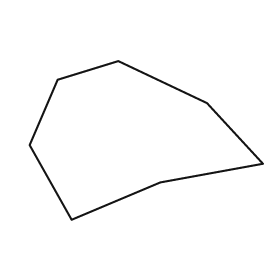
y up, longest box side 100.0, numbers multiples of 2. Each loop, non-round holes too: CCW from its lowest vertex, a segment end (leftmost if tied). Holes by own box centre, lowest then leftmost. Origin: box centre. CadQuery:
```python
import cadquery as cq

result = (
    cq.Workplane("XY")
    .moveTo(-32.0, -34.0)
    .lineTo(6.0, -18.0)
    .lineTo(50.0, -10.0)
    .lineTo(26.0, 16.0)
    .lineTo(-12.0, 34.0)
    .lineTo(-38.0, 26.0)
    .lineTo(-50.0, -2.0)
    .close()
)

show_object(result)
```